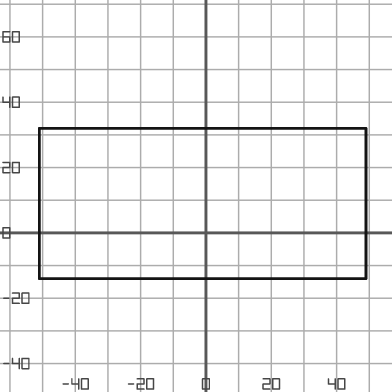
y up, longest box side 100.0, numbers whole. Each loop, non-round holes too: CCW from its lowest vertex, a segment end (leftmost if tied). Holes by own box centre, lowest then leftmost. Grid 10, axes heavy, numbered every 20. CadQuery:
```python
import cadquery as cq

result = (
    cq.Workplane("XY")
    .moveTo(-51.0, -14.0)
    .lineTo(49.0, -14.0)
    .lineTo(49.0, 32.0)
    .lineTo(-51.0, 32.0)
    .close()
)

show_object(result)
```